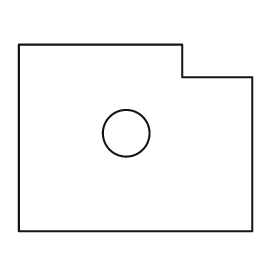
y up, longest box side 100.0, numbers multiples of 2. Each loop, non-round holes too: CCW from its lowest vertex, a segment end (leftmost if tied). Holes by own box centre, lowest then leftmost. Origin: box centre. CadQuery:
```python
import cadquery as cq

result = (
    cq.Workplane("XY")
    .moveTo(-50.0, -40.0)
    .lineTo(50.0, -40.0)
    .lineTo(50.0, 26.0)
    .lineTo(20.0, 26.0)
    .lineTo(20.0, 40.0)
    .lineTo(-50.0, 40.0)
    .close()
    .moveTo(-4.0, 2.0)
    .circle(10.0)
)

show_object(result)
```